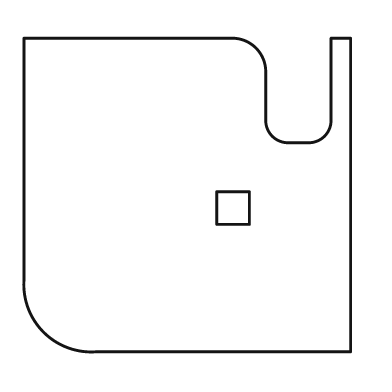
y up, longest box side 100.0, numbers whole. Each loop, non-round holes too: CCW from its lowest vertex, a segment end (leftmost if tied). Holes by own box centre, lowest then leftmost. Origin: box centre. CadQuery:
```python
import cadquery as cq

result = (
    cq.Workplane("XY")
    .moveTo(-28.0, -48.0)
    .lineTo(50.0, -48.0)
    .lineTo(50.0, 48.0)
    .lineTo(44.0, 48.0)
    .lineTo(44.0, 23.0)
    .threePointArc((42.0, 18.0), (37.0, 16.0))
    .lineTo(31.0, 16.0)
    .threePointArc((26.0, 18.0), (24.0, 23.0))
    .lineTo(24.0, 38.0)
    .threePointArc((21.0, 45.0), (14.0, 48.0))
    .lineTo(-50.0, 48.0)
    .lineTo(-50.0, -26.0)
    .threePointArc((-44.0, -42.0), (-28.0, -48.0))
    .close()
    .moveTo(9.0, -9.0)
    .lineTo(19.0, -9.0)
    .lineTo(19.0, 1.0)
    .lineTo(9.0, 1.0)
    .close()
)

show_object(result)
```